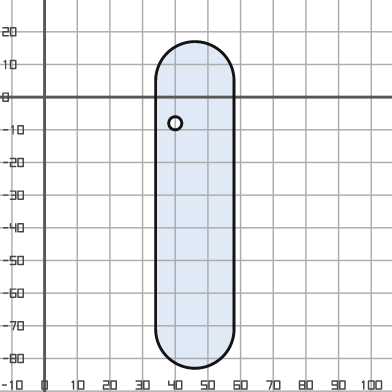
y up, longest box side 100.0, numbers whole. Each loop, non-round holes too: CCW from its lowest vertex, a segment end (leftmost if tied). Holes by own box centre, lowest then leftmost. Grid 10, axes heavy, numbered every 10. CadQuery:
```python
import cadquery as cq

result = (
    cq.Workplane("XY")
    .moveTo(34.0, -71.0)
    .threePointArc((46.0, -83.0), (58.0, -71.0))
    .lineTo(58.0, 5.0)
    .threePointArc((46.0, 17.0), (34.0, 5.0))
    .close()
    .moveTo(40.0, -8.0)
    .circle(2.0)
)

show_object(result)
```